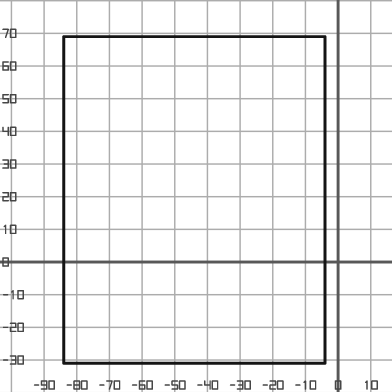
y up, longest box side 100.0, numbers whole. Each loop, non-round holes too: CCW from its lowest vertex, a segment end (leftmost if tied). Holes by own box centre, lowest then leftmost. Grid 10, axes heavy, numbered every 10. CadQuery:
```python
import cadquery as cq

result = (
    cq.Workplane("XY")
    .moveTo(-84.0, -31.0)
    .lineTo(-4.0, -31.0)
    .lineTo(-4.0, 69.0)
    .lineTo(-84.0, 69.0)
    .close()
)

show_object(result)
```